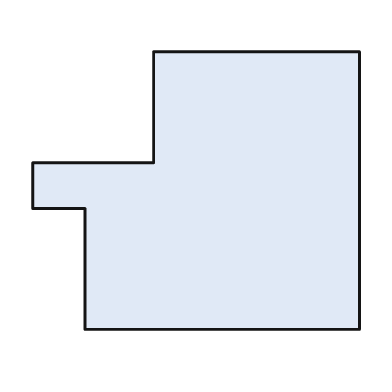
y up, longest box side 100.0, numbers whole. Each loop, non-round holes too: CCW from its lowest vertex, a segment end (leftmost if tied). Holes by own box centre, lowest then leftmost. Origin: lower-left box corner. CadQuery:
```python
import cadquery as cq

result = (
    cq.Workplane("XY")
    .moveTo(16.0, 0.0)
    .lineTo(100.0, 0.0)
    .lineTo(100.0, 85.0)
    .lineTo(37.0, 85.0)
    .lineTo(37.0, 51.0)
    .lineTo(0.0, 51.0)
    .lineTo(0.0, 37.0)
    .lineTo(16.0, 37.0)
    .close()
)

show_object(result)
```